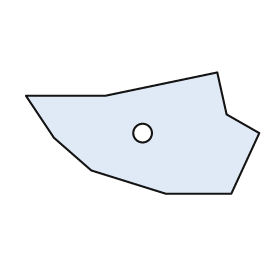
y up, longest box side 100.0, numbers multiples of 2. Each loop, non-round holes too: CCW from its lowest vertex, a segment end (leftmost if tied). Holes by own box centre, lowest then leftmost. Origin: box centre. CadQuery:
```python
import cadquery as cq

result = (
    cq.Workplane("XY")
    .moveTo(10.0, -26.0)
    .lineTo(38.0, -26.0)
    .lineTo(50.0, 0.0)
    .lineTo(36.0, 8.0)
    .lineTo(32.0, 26.0)
    .lineTo(-16.0, 16.0)
    .lineTo(-50.0, 16.0)
    .lineTo(-38.0, -2.0)
    .lineTo(-22.0, -16.0)
    .close()
    .moveTo(0.0, 0.0)
    .circle(4.0)
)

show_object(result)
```